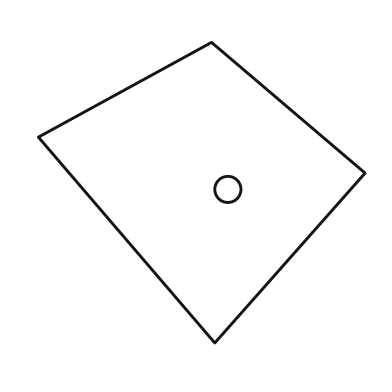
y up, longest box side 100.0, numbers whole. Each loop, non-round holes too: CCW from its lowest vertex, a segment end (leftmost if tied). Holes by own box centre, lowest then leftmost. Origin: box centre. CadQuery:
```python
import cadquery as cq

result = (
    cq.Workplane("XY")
    .moveTo(4.0, -46.0)
    .lineTo(50.0, 6.0)
    .lineTo(3.0, 46.0)
    .lineTo(-50.0, 17.0)
    .close()
    .moveTo(8.0, 1.0)
    .circle(4.0)
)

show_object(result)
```